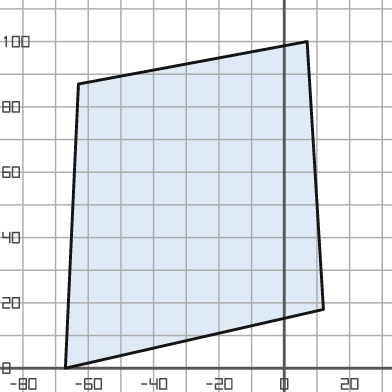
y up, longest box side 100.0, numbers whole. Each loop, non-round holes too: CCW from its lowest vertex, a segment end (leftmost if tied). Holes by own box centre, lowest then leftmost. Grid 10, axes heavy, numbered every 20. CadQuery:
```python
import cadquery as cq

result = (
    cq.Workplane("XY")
    .moveTo(-67.0, 0.0)
    .lineTo(12.0, 18.0)
    .lineTo(7.0, 100.0)
    .lineTo(-63.0, 87.0)
    .close()
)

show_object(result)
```